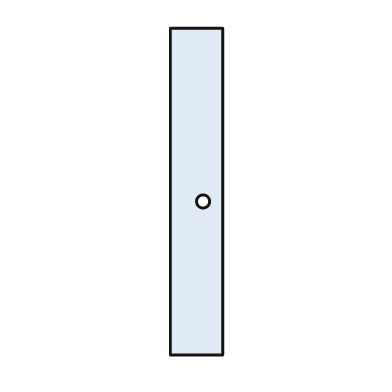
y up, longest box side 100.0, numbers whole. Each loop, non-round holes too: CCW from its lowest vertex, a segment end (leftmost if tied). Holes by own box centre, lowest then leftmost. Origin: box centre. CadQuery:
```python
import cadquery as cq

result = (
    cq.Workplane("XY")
    .moveTo(-8.0, -50.0)
    .lineTo(8.0, -50.0)
    .lineTo(8.0, 50.0)
    .lineTo(-8.0, 50.0)
    .close()
    .moveTo(2.0, -3.0)
    .circle(2.0)
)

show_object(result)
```